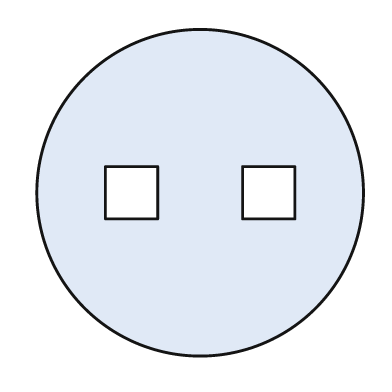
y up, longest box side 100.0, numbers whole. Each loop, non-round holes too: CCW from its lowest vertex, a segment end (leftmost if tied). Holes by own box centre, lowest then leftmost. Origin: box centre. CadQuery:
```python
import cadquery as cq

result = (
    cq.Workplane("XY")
    .moveTo(0.0, 0.0)
    .circle(50.0)
    .moveTo(-29.0, -8.0)
    .lineTo(-13.0, -8.0)
    .lineTo(-13.0, 8.0)
    .lineTo(-29.0, 8.0)
    .close()
    .moveTo(13.0, -8.0)
    .lineTo(29.0, -8.0)
    .lineTo(29.0, 8.0)
    .lineTo(13.0, 8.0)
    .close()
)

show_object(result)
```